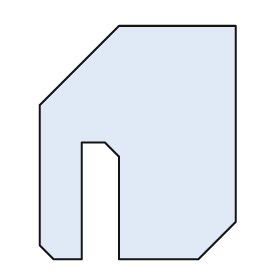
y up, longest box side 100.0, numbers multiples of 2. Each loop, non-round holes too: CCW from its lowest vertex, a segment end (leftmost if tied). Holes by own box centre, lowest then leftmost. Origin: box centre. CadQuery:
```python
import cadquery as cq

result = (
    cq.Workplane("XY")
    .moveTo(-36.0, -50.0)
    .lineTo(-24.0, -50.0)
    .lineTo(-24.0, 0.0)
    .lineTo(-14.0, 0.0)
    .lineTo(-8.0, -6.0)
    .lineTo(-8.0, -50.0)
    .lineTo(26.0, -50.0)
    .lineTo(42.0, -34.0)
    .lineTo(42.0, 50.0)
    .lineTo(-8.0, 50.0)
    .lineTo(-42.0, 16.0)
    .lineTo(-42.0, -44.0)
    .close()
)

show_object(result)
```